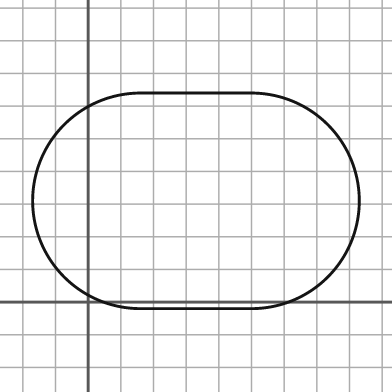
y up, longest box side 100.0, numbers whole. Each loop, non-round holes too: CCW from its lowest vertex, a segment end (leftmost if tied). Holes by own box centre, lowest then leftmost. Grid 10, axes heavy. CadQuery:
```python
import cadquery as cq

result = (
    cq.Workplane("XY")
    .moveTo(16.0, -2.0)
    .lineTo(50.0, -2.0)
    .threePointArc((83.0, 31.0), (50.0, 64.0))
    .lineTo(16.0, 64.0)
    .threePointArc((-17.0, 31.0), (16.0, -2.0))
    .close()
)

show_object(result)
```